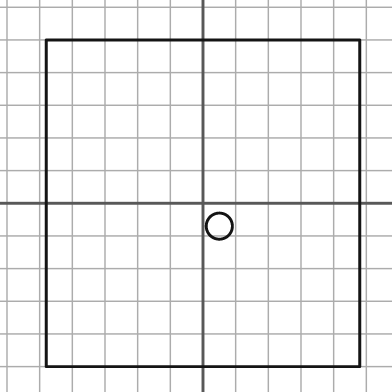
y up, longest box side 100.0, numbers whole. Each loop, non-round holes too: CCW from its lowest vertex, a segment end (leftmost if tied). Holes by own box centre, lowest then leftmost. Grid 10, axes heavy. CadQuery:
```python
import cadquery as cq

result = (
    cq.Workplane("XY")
    .moveTo(-48.0, -50.0)
    .lineTo(48.0, -50.0)
    .lineTo(48.0, 50.0)
    .lineTo(-48.0, 50.0)
    .close()
    .moveTo(5.0, -7.0)
    .circle(4.0)
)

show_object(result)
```